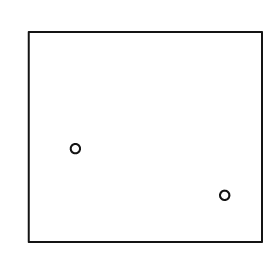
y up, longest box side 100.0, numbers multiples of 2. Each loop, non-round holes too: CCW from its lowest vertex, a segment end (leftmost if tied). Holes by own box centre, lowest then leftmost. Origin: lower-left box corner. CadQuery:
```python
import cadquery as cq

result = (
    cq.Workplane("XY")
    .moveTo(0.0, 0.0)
    .lineTo(100.0, 0.0)
    .lineTo(100.0, 90.0)
    .lineTo(0.0, 90.0)
    .close()
    .moveTo(84.0, 20.0)
    .circle(2.0)
    .moveTo(20.0, 40.0)
    .circle(2.0)
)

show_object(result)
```